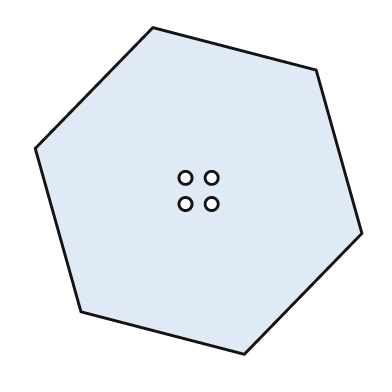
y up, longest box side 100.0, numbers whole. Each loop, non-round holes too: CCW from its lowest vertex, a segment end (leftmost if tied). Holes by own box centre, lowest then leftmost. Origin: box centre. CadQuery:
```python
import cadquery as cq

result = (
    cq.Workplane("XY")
    .moveTo(14.0, -50.0)
    .lineTo(50.0, -13.0)
    .lineTo(36.0, 37.0)
    .lineTo(-14.0, 50.0)
    .lineTo(-50.0, 13.0)
    .lineTo(-36.0, -37.0)
    .close()
    .moveTo(-4.0, -4.0)
    .circle(2.0)
    .moveTo(4.0, -4.0)
    .circle(2.0)
    .moveTo(-4.0, 4.0)
    .circle(2.0)
    .moveTo(4.0, 4.0)
    .circle(2.0)
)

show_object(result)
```